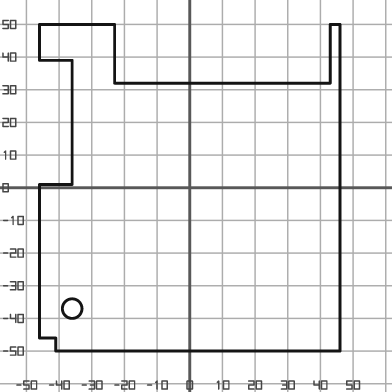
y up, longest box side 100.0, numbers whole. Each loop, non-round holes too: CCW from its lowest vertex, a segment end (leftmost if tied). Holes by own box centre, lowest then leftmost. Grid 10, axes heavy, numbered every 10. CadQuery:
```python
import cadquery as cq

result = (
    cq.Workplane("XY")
    .moveTo(-41.0, -50.0)
    .lineTo(46.0, -50.0)
    .lineTo(46.0, 50.0)
    .lineTo(43.0, 50.0)
    .lineTo(43.0, 32.0)
    .lineTo(-23.0, 32.0)
    .lineTo(-23.0, 50.0)
    .lineTo(-46.0, 50.0)
    .lineTo(-46.0, 39.0)
    .lineTo(-36.0, 39.0)
    .lineTo(-36.0, 1.0)
    .lineTo(-46.0, 1.0)
    .lineTo(-46.0, -46.0)
    .lineTo(-41.0, -46.0)
    .close()
    .moveTo(-36.0, -37.0)
    .circle(3.0)
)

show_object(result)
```